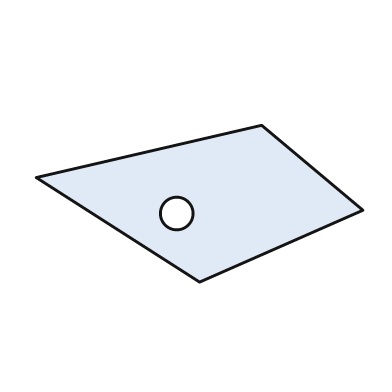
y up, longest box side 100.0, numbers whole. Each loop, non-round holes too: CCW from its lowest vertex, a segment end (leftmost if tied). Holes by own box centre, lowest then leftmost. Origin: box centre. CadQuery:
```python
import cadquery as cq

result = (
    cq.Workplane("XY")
    .moveTo(0.0, -24.0)
    .lineTo(50.0, -2.0)
    .lineTo(19.0, 24.0)
    .lineTo(-50.0, 8.0)
    .close()
    .moveTo(-7.0, -3.0)
    .circle(5.0)
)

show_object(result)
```